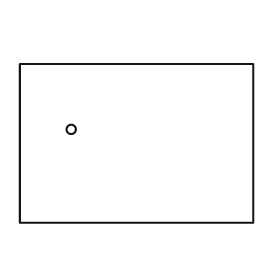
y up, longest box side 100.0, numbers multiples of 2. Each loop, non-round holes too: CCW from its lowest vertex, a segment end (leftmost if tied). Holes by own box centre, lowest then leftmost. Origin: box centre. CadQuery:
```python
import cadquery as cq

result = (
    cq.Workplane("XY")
    .moveTo(-50.0, -34.0)
    .lineTo(50.0, -34.0)
    .lineTo(50.0, 34.0)
    .lineTo(-50.0, 34.0)
    .close()
    .moveTo(-28.0, 6.0)
    .circle(2.0)
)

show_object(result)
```